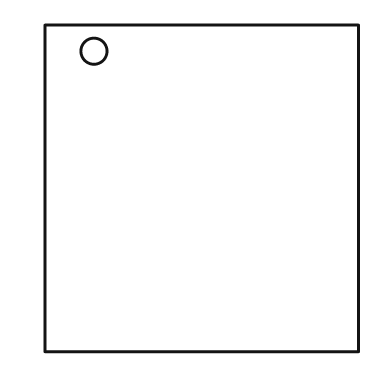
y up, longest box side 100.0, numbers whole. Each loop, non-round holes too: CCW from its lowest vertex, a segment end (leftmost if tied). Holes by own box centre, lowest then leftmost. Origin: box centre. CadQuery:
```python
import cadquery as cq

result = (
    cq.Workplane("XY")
    .moveTo(-48.0, -50.0)
    .lineTo(48.0, -50.0)
    .lineTo(48.0, 50.0)
    .lineTo(-48.0, 50.0)
    .close()
    .moveTo(-33.0, 42.0)
    .circle(4.0)
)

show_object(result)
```